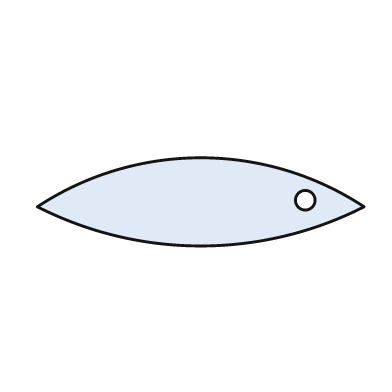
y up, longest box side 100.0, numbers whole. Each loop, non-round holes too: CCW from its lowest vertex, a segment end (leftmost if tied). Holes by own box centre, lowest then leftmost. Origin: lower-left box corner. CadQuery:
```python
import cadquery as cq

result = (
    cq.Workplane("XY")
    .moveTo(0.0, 12.0)
    .threePointArc((50.0, 0.0), (100.0, 12.0))
    .threePointArc((50.0, 27.0), (0.0, 12.0))
    .close()
    .moveTo(82.0, 14.0)
    .circle(3.0)
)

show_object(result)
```